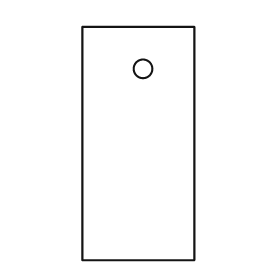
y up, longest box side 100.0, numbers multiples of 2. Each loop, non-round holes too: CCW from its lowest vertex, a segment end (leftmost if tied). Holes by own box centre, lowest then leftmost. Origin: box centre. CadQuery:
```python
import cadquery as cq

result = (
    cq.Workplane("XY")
    .moveTo(-24.0, -50.0)
    .lineTo(24.0, -50.0)
    .lineTo(24.0, 50.0)
    .lineTo(-24.0, 50.0)
    .close()
    .moveTo(2.0, 32.0)
    .circle(4.0)
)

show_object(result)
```